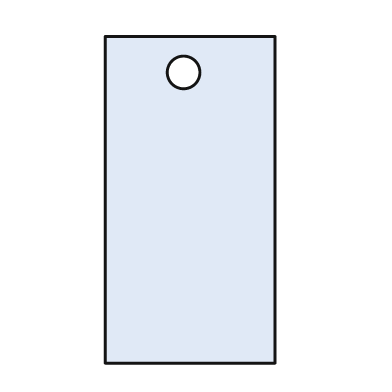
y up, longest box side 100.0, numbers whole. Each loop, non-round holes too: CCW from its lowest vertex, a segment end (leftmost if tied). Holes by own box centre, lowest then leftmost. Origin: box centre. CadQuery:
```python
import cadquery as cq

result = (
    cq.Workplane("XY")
    .moveTo(-26.0, -50.0)
    .lineTo(26.0, -50.0)
    .lineTo(26.0, 50.0)
    .lineTo(-26.0, 50.0)
    .close()
    .moveTo(-2.0, 39.0)
    .circle(5.0)
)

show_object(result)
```